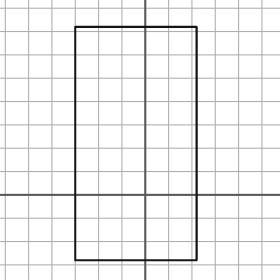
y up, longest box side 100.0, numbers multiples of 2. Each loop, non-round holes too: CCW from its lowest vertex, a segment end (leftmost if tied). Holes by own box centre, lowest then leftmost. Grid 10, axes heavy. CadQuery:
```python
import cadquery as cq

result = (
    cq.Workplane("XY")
    .moveTo(-30.0, -28.0)
    .lineTo(22.0, -28.0)
    .lineTo(22.0, 72.0)
    .lineTo(-30.0, 72.0)
    .close()
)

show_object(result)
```